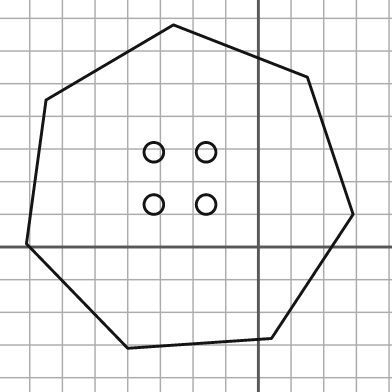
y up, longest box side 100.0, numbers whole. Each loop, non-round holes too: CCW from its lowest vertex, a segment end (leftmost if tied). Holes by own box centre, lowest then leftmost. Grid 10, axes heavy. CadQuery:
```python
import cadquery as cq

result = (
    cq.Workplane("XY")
    .moveTo(-40.0, -31.0)
    .lineTo(4.0, -28.0)
    .lineTo(29.0, 10.0)
    .lineTo(15.0, 52.0)
    .lineTo(-26.0, 68.0)
    .lineTo(-65.0, 45.0)
    .lineTo(-71.0, 1.0)
    .close()
    .moveTo(-32.0, 13.0)
    .circle(3.0)
    .moveTo(-16.0, 13.0)
    .circle(3.0)
    .moveTo(-32.0, 29.0)
    .circle(3.0)
    .moveTo(-16.0, 29.0)
    .circle(3.0)
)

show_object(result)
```